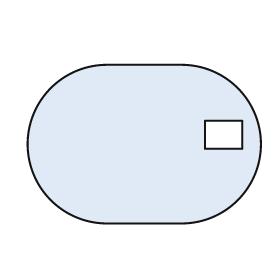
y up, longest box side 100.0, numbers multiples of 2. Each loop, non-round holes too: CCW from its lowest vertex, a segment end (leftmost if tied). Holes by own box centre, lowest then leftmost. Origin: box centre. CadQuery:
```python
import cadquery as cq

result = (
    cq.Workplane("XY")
    .moveTo(-16.0, -34.0)
    .lineTo(16.0, -34.0)
    .threePointArc((50.0, 0.0), (16.0, 34.0))
    .lineTo(-16.0, 34.0)
    .threePointArc((-50.0, 0.0), (-16.0, -34.0))
    .close()
    .moveTo(26.0, -2.0)
    .lineTo(42.0, -2.0)
    .lineTo(42.0, 10.0)
    .lineTo(26.0, 10.0)
    .close()
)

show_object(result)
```